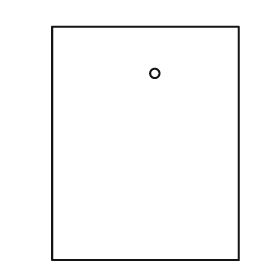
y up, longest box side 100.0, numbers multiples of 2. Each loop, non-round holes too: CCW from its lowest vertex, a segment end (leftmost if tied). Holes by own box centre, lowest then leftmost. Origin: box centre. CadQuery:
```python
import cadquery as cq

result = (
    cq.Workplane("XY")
    .moveTo(-40.0, -50.0)
    .lineTo(40.0, -50.0)
    .lineTo(40.0, 50.0)
    .lineTo(-40.0, 50.0)
    .close()
    .moveTo(4.0, 30.0)
    .circle(2.0)
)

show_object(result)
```